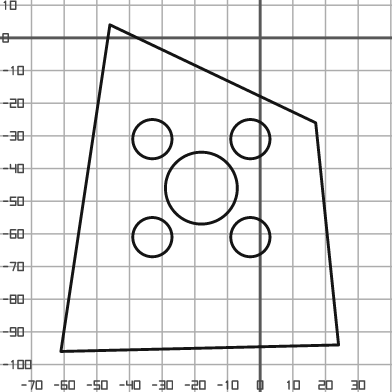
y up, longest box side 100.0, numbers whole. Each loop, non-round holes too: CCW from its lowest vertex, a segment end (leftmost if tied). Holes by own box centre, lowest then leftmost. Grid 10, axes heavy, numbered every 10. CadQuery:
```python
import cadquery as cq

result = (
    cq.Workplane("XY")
    .moveTo(-61.0, -96.0)
    .lineTo(24.0, -94.0)
    .lineTo(17.0, -26.0)
    .lineTo(-46.0, 4.0)
    .close()
    .moveTo(-33.0, -61.0)
    .circle(6.0)
    .moveTo(-3.0, -61.0)
    .circle(6.0)
    .moveTo(-18.0, -46.0)
    .circle(11.0)
    .moveTo(-33.0, -31.0)
    .circle(6.0)
    .moveTo(-3.0, -31.0)
    .circle(6.0)
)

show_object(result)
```